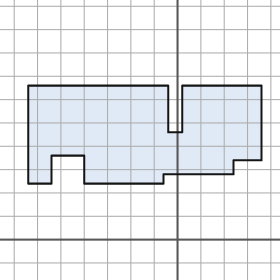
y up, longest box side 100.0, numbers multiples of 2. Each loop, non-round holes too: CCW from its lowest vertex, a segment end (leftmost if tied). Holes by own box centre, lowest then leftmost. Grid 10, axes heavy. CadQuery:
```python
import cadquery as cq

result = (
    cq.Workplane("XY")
    .moveTo(-64.0, 24.0)
    .lineTo(-54.0, 24.0)
    .lineTo(-54.0, 36.0)
    .lineTo(-40.0, 36.0)
    .lineTo(-40.0, 24.0)
    .lineTo(-6.0, 24.0)
    .lineTo(-6.0, 28.0)
    .lineTo(24.0, 28.0)
    .lineTo(24.0, 34.0)
    .lineTo(36.0, 34.0)
    .lineTo(36.0, 66.0)
    .lineTo(2.0, 66.0)
    .lineTo(2.0, 46.0)
    .lineTo(-4.0, 46.0)
    .lineTo(-4.0, 66.0)
    .lineTo(-64.0, 66.0)
    .close()
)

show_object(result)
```